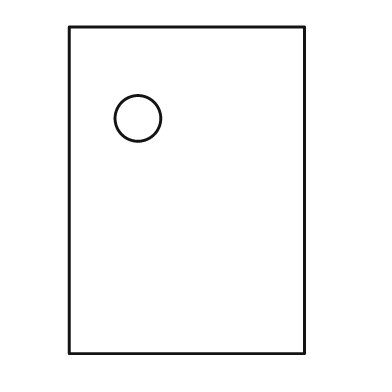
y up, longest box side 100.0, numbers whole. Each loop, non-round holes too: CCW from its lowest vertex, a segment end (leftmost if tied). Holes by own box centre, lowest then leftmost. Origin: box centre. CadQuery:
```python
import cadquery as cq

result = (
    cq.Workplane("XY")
    .moveTo(-36.0, -50.0)
    .lineTo(36.0, -50.0)
    .lineTo(36.0, 50.0)
    .lineTo(-36.0, 50.0)
    .close()
    .moveTo(-15.0, 22.0)
    .circle(7.0)
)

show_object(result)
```